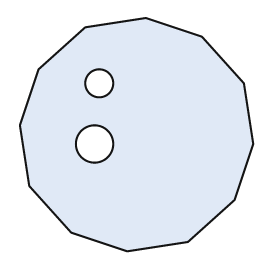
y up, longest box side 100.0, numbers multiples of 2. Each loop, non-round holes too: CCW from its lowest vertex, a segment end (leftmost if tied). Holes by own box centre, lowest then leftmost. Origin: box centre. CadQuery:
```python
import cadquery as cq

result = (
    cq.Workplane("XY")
    .moveTo(-4.0, -50.0)
    .lineTo(22.0, -46.0)
    .lineTo(42.0, -28.0)
    .lineTo(50.0, -4.0)
    .lineTo(46.0, 22.0)
    .lineTo(28.0, 42.0)
    .lineTo(4.0, 50.0)
    .lineTo(-22.0, 46.0)
    .lineTo(-42.0, 28.0)
    .lineTo(-50.0, 4.0)
    .lineTo(-46.0, -22.0)
    .lineTo(-28.0, -42.0)
    .close()
    .moveTo(-18.0, -4.0)
    .circle(8.0)
    .moveTo(-16.0, 22.0)
    .circle(6.0)
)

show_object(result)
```